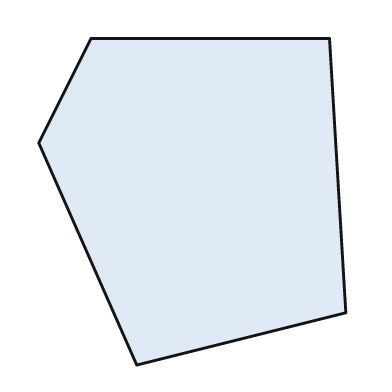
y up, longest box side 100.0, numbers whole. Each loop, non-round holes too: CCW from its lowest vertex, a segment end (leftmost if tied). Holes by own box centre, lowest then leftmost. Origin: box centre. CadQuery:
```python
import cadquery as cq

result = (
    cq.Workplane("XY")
    .moveTo(-17.0, -50.0)
    .lineTo(47.0, -34.0)
    .lineTo(42.0, 50.0)
    .lineTo(-31.0, 50.0)
    .lineTo(-47.0, 18.0)
    .close()
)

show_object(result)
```